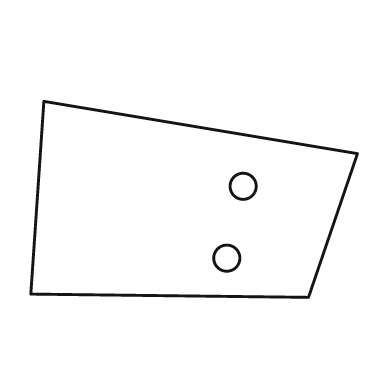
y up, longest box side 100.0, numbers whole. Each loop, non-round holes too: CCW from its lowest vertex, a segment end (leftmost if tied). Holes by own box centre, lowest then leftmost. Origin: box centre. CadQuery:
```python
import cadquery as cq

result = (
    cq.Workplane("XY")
    .moveTo(35.0, -30.0)
    .lineTo(50.0, 14.0)
    .lineTo(-46.0, 30.0)
    .lineTo(-50.0, -29.0)
    .close()
    .moveTo(10.0, -18.0)
    .circle(4.0)
    .moveTo(15.0, 4.0)
    .circle(4.0)
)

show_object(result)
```